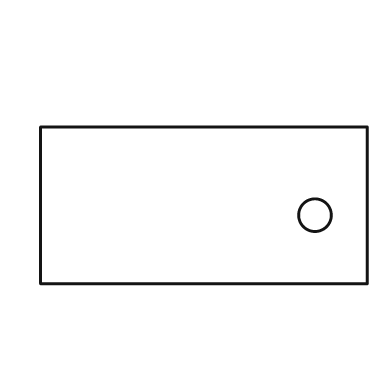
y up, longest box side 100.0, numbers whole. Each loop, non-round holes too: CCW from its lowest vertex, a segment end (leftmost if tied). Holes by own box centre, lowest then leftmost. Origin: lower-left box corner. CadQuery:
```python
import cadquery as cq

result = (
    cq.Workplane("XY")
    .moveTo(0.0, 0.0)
    .lineTo(100.0, 0.0)
    .lineTo(100.0, 48.0)
    .lineTo(0.0, 48.0)
    .close()
    .moveTo(84.0, 21.0)
    .circle(5.0)
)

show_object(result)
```